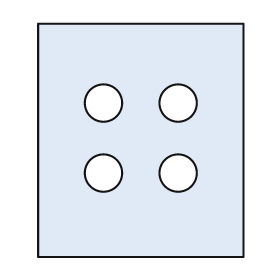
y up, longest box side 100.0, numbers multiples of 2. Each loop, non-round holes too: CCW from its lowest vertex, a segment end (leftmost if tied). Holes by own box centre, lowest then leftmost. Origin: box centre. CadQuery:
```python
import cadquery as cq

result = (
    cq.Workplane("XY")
    .moveTo(-44.0, -50.0)
    .lineTo(44.0, -50.0)
    .lineTo(44.0, 50.0)
    .lineTo(-44.0, 50.0)
    .close()
    .moveTo(-16.0, -14.0)
    .circle(8.0)
    .moveTo(16.0, -14.0)
    .circle(8.0)
    .moveTo(-16.0, 16.0)
    .circle(8.0)
    .moveTo(16.0, 16.0)
    .circle(8.0)
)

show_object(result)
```